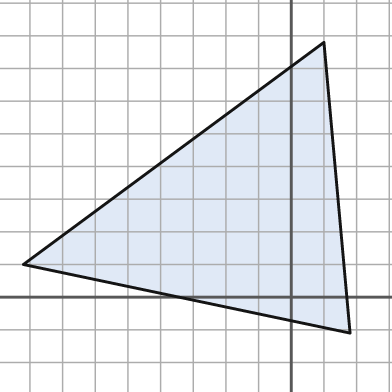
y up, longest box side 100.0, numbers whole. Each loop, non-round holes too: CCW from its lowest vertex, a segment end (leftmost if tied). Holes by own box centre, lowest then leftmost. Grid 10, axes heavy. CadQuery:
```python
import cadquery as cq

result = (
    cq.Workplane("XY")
    .moveTo(18.0, -11.0)
    .lineTo(10.0, 78.0)
    .lineTo(-82.0, 10.0)
    .close()
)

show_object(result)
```